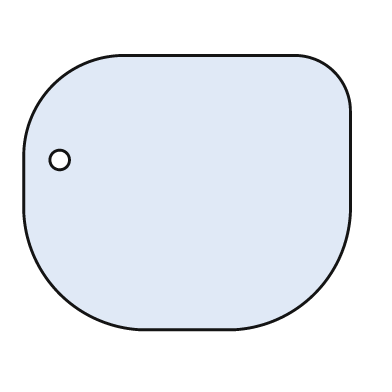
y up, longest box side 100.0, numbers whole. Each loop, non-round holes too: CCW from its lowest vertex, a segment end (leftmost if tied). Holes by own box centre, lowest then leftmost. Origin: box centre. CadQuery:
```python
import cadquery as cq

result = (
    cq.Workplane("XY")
    .moveTo(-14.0, -42.0)
    .lineTo(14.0, -42.0)
    .threePointArc((39.0, -31.0), (50.0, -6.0))
    .lineTo(50.0, 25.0)
    .threePointArc((45.0, 37.0), (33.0, 42.0))
    .lineTo(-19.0, 42.0)
    .threePointArc((-41.0, 33.0), (-50.0, 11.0))
    .lineTo(-50.0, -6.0)
    .threePointArc((-39.0, -31.0), (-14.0, -42.0))
    .close()
    .moveTo(-39.0, 10.0)
    .circle(3.0)
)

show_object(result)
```